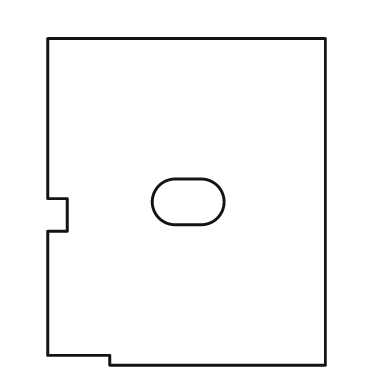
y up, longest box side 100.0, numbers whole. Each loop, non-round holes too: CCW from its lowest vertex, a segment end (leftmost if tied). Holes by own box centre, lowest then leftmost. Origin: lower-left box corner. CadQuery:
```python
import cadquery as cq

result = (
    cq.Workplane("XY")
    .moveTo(19.0, 0.0)
    .lineTo(85.0, 0.0)
    .lineTo(85.0, 100.0)
    .lineTo(0.0, 100.0)
    .lineTo(0.0, 51.0)
    .lineTo(6.0, 51.0)
    .lineTo(6.0, 41.0)
    .lineTo(0.0, 41.0)
    .lineTo(0.0, 3.0)
    .lineTo(19.0, 3.0)
    .close()
    .moveTo(39.0, 43.0)
    .lineTo(47.0, 43.0)
    .threePointArc((54.0, 50.0), (47.0, 57.0))
    .lineTo(39.0, 57.0)
    .threePointArc((32.0, 50.0), (39.0, 43.0))
    .close()
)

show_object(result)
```